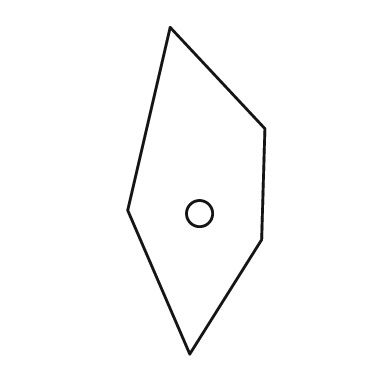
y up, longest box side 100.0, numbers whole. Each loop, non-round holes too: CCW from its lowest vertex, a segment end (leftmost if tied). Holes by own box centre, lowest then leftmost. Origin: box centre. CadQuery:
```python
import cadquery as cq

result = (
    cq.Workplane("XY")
    .moveTo(-2.0, -50.0)
    .lineTo(20.0, -15.0)
    .lineTo(21.0, 19.0)
    .lineTo(-8.0, 50.0)
    .lineTo(-21.0, -6.0)
    .close()
    .moveTo(1.0, -7.0)
    .circle(4.0)
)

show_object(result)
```